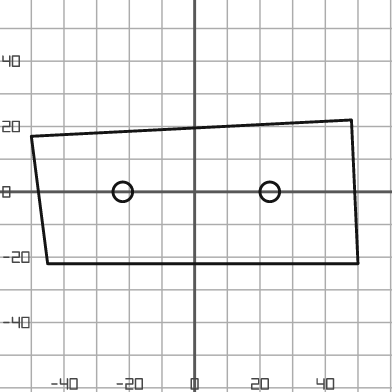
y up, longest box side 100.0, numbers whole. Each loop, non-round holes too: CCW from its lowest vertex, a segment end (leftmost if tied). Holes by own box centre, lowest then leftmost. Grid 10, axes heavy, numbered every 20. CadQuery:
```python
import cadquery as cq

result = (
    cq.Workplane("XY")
    .moveTo(-45.0, -22.0)
    .lineTo(50.0, -22.0)
    .lineTo(48.0, 22.0)
    .lineTo(-50.0, 17.0)
    .close()
    .moveTo(-22.0, 0.0)
    .circle(3.0)
    .moveTo(23.0, 0.0)
    .circle(3.0)
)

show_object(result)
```